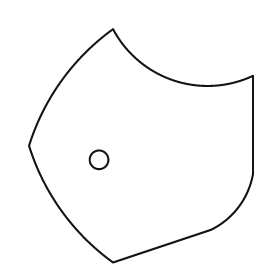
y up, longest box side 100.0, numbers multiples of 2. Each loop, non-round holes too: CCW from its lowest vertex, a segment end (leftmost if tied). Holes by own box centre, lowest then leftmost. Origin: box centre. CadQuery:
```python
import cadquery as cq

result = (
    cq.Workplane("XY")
    .moveTo(-12.0, -50.0)
    .lineTo(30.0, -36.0)
    .threePointArc((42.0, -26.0), (48.0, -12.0))
    .lineTo(48.0, 30.0)
    .threePointArc((14.0, 28.0), (-12.0, 50.0))
    .threePointArc((-34.0, 28.0), (-48.0, 0.0))
    .threePointArc((-34.0, -28.0), (-12.0, -50.0))
    .close()
    .moveTo(-18.0, -6.0)
    .circle(4.0)
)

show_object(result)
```